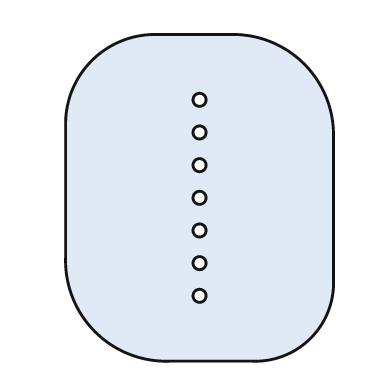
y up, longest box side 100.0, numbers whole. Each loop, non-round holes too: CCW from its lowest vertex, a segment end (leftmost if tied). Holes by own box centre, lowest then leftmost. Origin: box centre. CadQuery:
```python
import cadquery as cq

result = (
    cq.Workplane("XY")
    .moveTo(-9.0, -50.0)
    .lineTo(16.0, -50.0)
    .threePointArc((34.0, -43.0), (41.0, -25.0))
    .lineTo(41.0, 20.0)
    .threePointArc((32.0, 41.0), (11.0, 50.0))
    .lineTo(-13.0, 50.0)
    .threePointArc((-33.0, 42.0), (-41.0, 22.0))
    .lineTo(-41.0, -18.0)
    .threePointArc((-32.0, -41.0), (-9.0, -50.0))
    .close()
    .moveTo(0.0, -30.0)
    .circle(2.0)
    .moveTo(0.0, -20.0)
    .circle(2.0)
    .moveTo(0.0, -10.0)
    .circle(2.0)
    .moveTo(0.0, 0.0)
    .circle(2.0)
    .moveTo(0.0, 10.0)
    .circle(2.0)
    .moveTo(0.0, 20.0)
    .circle(2.0)
    .moveTo(0.0, 30.0)
    .circle(2.0)
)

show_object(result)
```